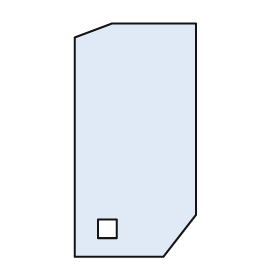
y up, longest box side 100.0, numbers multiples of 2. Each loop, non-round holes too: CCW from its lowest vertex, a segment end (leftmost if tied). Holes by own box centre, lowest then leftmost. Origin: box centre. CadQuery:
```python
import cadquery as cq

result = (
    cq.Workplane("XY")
    .moveTo(-26.0, -50.0)
    .lineTo(12.0, -50.0)
    .lineTo(26.0, -32.0)
    .lineTo(26.0, 50.0)
    .lineTo(-10.0, 50.0)
    .lineTo(-26.0, 44.0)
    .close()
    .moveTo(-16.0, -42.0)
    .lineTo(-8.0, -42.0)
    .lineTo(-8.0, -34.0)
    .lineTo(-16.0, -34.0)
    .close()
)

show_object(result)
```